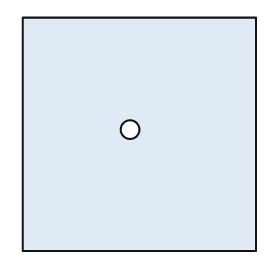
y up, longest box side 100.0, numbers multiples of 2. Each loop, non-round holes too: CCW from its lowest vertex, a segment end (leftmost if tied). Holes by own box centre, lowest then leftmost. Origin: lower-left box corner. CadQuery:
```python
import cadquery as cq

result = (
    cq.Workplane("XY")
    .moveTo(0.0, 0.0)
    .lineTo(100.0, 0.0)
    .lineTo(100.0, 100.0)
    .lineTo(0.0, 100.0)
    .close()
    .moveTo(46.0, 52.0)
    .circle(4.0)
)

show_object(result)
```